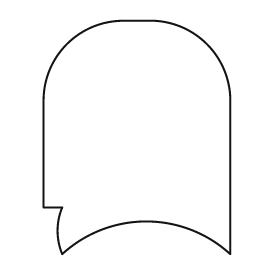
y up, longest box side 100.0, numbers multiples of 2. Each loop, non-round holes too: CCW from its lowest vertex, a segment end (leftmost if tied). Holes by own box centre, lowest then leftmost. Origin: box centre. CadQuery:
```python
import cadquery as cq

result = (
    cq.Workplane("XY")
    .moveTo(-32.0, -50.0)
    .threePointArc((4.0, -36.0), (40.0, -50.0))
    .lineTo(40.0, 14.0)
    .threePointArc((30.0, 40.0), (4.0, 50.0))
    .lineTo(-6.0, 50.0)
    .threePointArc((-30.0, 40.0), (-40.0, 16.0))
    .lineTo(-40.0, -30.0)
    .lineTo(-32.0, -30.0)
    .threePointArc((-34.0, -40.0), (-32.0, -50.0))
    .close()
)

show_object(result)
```